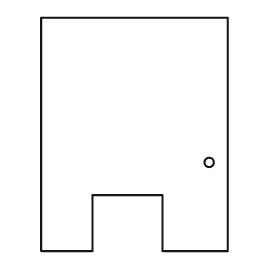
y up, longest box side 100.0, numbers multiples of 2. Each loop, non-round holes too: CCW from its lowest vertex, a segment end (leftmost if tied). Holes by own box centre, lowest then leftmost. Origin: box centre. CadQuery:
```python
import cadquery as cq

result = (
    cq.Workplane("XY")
    .moveTo(-40.0, -50.0)
    .lineTo(-18.0, -50.0)
    .lineTo(-18.0, -26.0)
    .lineTo(12.0, -26.0)
    .lineTo(12.0, -50.0)
    .lineTo(40.0, -50.0)
    .lineTo(40.0, 50.0)
    .lineTo(-40.0, 50.0)
    .close()
    .moveTo(32.0, -12.0)
    .circle(2.0)
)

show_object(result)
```